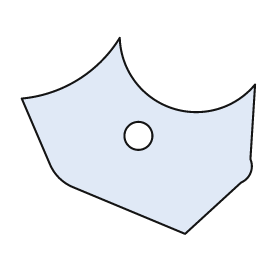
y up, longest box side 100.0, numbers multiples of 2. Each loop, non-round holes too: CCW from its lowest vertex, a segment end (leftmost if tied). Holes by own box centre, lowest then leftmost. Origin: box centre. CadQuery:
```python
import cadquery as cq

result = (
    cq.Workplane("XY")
    .moveTo(20.0, -42.0)
    .lineTo(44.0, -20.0)
    .threePointArc((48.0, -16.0), (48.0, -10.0))
    .lineTo(50.0, 22.0)
    .threePointArc((14.0, 12.0), (-8.0, 42.0))
    .threePointArc((-26.0, 24.0), (-50.0, 16.0))
    .lineTo(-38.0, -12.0)
    .threePointArc((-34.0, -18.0), (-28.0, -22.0))
    .close()
    .moveTo(0.0, 0.0)
    .circle(6.0)
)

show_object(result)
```